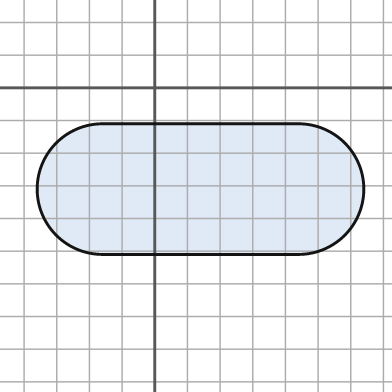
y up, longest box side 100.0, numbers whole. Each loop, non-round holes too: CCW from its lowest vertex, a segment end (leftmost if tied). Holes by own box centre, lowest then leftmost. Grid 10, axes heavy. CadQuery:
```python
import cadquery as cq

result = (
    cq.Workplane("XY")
    .moveTo(-16.0, -51.0)
    .lineTo(44.0, -51.0)
    .threePointArc((64.0, -31.0), (44.0, -11.0))
    .lineTo(-16.0, -11.0)
    .threePointArc((-36.0, -31.0), (-16.0, -51.0))
    .close()
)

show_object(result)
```